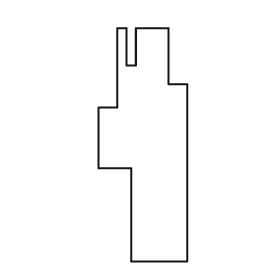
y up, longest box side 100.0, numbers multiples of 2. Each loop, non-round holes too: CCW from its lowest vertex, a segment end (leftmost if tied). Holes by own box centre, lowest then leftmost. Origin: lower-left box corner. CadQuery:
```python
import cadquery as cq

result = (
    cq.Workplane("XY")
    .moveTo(14.0, 0.0)
    .lineTo(38.0, 0.0)
    .lineTo(38.0, 76.0)
    .lineTo(30.0, 76.0)
    .lineTo(30.0, 100.0)
    .lineTo(16.0, 100.0)
    .lineTo(16.0, 84.0)
    .lineTo(12.0, 84.0)
    .lineTo(12.0, 100.0)
    .lineTo(8.0, 100.0)
    .lineTo(8.0, 66.0)
    .lineTo(0.0, 66.0)
    .lineTo(0.0, 40.0)
    .lineTo(14.0, 40.0)
    .close()
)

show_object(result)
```